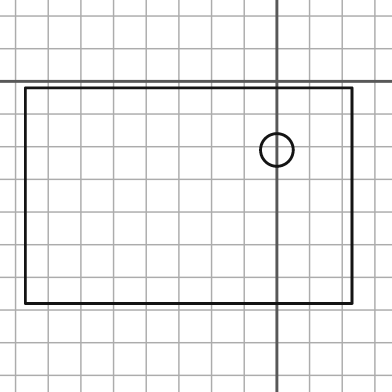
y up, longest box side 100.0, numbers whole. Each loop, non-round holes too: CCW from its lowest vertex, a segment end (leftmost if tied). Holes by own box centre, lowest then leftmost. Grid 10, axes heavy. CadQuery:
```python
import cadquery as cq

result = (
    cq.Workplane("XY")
    .moveTo(-77.0, -68.0)
    .lineTo(23.0, -68.0)
    .lineTo(23.0, -2.0)
    .lineTo(-77.0, -2.0)
    .close()
    .moveTo(0.0, -21.0)
    .circle(5.0)
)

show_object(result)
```